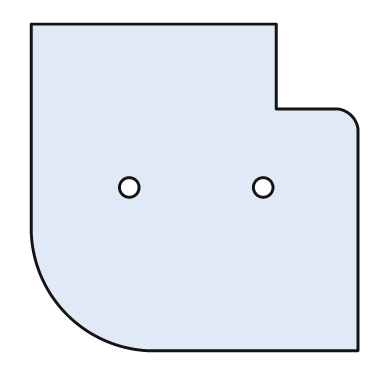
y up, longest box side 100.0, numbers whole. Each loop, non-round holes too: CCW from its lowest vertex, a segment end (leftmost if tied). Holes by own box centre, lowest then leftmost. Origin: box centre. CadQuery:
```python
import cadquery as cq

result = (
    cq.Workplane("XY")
    .moveTo(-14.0, -50.0)
    .lineTo(50.0, -50.0)
    .lineTo(50.0, 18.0)
    .threePointArc((48.0, 22.0), (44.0, 24.0))
    .lineTo(25.0, 24.0)
    .lineTo(25.0, 50.0)
    .lineTo(-50.0, 50.0)
    .lineTo(-50.0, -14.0)
    .threePointArc((-39.0, -39.0), (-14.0, -50.0))
    .close()
    .moveTo(-20.0, 0.0)
    .circle(3.0)
    .moveTo(21.0, 0.0)
    .circle(3.0)
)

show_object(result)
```